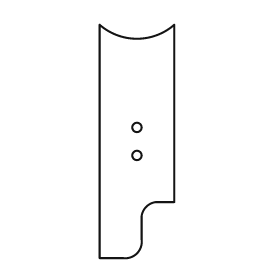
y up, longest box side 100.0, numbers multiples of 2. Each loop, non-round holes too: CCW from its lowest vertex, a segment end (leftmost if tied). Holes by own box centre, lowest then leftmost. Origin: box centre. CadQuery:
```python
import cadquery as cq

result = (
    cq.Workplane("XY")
    .moveTo(-16.0, -50.0)
    .lineTo(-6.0, -50.0)
    .threePointArc((0.0, -48.0), (2.0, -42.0))
    .lineTo(2.0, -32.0)
    .threePointArc((4.0, -28.0), (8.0, -26.0))
    .lineTo(16.0, -26.0)
    .lineTo(16.0, 50.0)
    .threePointArc((0.0, 44.0), (-16.0, 50.0))
    .close()
    .moveTo(0.0, -6.0)
    .circle(2.0)
    .moveTo(0.0, 6.0)
    .circle(2.0)
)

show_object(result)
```